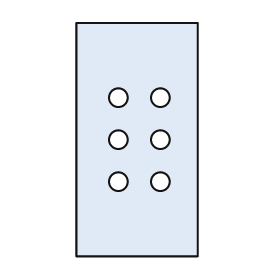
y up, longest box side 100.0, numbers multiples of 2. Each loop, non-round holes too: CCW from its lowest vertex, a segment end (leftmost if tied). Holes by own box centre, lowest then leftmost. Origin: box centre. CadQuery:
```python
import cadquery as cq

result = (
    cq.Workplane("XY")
    .moveTo(-26.0, -50.0)
    .lineTo(26.0, -50.0)
    .lineTo(26.0, 50.0)
    .lineTo(-26.0, 50.0)
    .close()
    .moveTo(-8.0, -18.0)
    .circle(4.0)
    .moveTo(10.0, -18.0)
    .circle(4.0)
    .moveTo(-8.0, 0.0)
    .circle(4.0)
    .moveTo(10.0, 0.0)
    .circle(4.0)
    .moveTo(-8.0, 18.0)
    .circle(4.0)
    .moveTo(10.0, 18.0)
    .circle(4.0)
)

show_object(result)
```